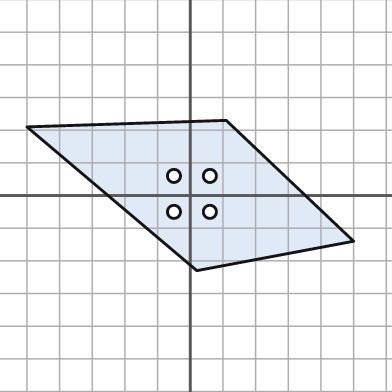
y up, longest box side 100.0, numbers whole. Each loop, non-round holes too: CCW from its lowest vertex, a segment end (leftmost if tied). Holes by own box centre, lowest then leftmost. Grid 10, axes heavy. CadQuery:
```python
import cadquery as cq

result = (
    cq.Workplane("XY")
    .moveTo(2.0, -23.0)
    .lineTo(50.0, -14.0)
    .lineTo(11.0, 23.0)
    .lineTo(-50.0, 21.0)
    .close()
    .moveTo(-5.0, -5.0)
    .circle(2.0)
    .moveTo(6.0, -5.0)
    .circle(2.0)
    .moveTo(-5.0, 6.0)
    .circle(2.0)
    .moveTo(6.0, 6.0)
    .circle(2.0)
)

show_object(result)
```